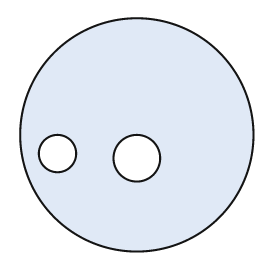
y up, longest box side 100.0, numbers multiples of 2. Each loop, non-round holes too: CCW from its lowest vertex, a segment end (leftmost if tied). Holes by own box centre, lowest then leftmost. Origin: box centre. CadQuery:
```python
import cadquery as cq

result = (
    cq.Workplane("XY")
    .moveTo(0.0, 0.0)
    .circle(50.0)
    .moveTo(0.0, -10.0)
    .circle(10.0)
    .moveTo(-34.0, -8.0)
    .circle(8.0)
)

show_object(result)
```